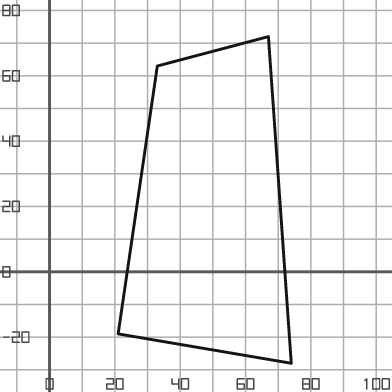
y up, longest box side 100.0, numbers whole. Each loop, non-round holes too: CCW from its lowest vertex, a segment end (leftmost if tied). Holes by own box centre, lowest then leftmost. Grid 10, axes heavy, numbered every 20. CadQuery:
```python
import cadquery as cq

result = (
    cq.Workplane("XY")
    .moveTo(74.0, -28.0)
    .lineTo(67.0, 72.0)
    .lineTo(33.0, 63.0)
    .lineTo(21.0, -19.0)
    .close()
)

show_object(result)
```